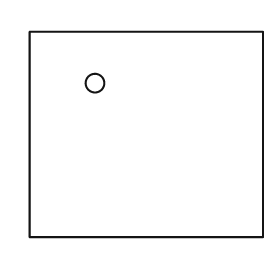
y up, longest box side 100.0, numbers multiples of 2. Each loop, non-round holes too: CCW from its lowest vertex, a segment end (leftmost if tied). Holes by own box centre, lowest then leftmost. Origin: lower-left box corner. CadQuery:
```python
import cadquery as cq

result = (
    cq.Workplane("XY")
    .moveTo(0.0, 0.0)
    .lineTo(100.0, 0.0)
    .lineTo(100.0, 88.0)
    .lineTo(0.0, 88.0)
    .close()
    .moveTo(28.0, 66.0)
    .circle(4.0)
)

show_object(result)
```